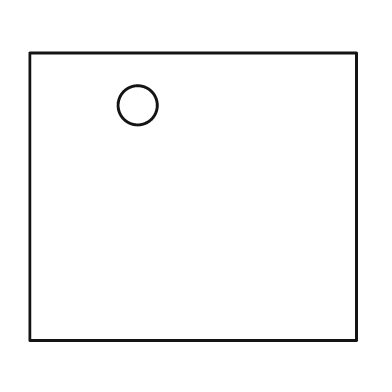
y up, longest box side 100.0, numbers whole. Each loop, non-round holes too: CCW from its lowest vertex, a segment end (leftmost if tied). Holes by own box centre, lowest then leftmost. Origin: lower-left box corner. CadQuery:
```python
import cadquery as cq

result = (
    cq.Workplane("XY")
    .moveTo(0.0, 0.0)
    .lineTo(100.0, 0.0)
    .lineTo(100.0, 88.0)
    .lineTo(0.0, 88.0)
    .close()
    .moveTo(33.0, 72.0)
    .circle(6.0)
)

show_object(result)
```